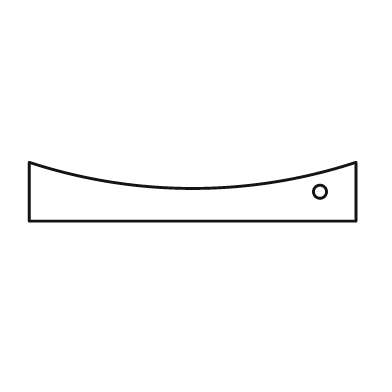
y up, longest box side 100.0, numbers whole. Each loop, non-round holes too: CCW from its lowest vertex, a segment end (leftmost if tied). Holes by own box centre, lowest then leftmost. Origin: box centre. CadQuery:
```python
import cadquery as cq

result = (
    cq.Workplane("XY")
    .moveTo(-50.0, -9.0)
    .lineTo(50.0, -9.0)
    .lineTo(50.0, 9.0)
    .threePointArc((0.0, 1.0), (-50.0, 9.0))
    .close()
    .moveTo(39.0, 0.0)
    .circle(2.0)
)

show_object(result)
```